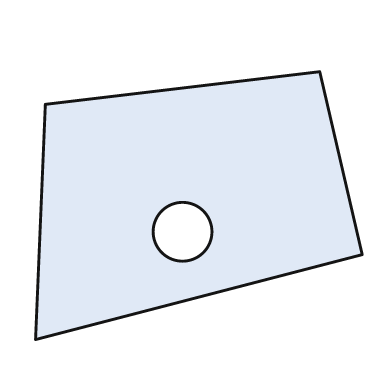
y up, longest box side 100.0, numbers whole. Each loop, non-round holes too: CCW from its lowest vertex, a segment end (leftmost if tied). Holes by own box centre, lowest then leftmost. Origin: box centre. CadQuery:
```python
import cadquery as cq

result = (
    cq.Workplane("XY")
    .moveTo(-50.0, -41.0)
    .lineTo(50.0, -15.0)
    .lineTo(37.0, 41.0)
    .lineTo(-47.0, 31.0)
    .close()
    .moveTo(-5.0, -8.0)
    .circle(9.0)
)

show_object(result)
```